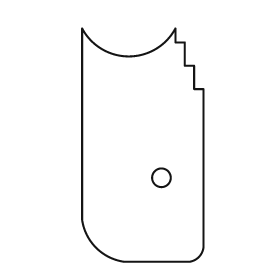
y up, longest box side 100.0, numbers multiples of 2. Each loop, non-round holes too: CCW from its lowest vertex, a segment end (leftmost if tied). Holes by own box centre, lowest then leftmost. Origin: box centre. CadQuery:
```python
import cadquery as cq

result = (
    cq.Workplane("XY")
    .moveTo(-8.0, -50.0)
    .lineTo(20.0, -50.0)
    .threePointArc((24.0, -48.0), (26.0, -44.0))
    .lineTo(26.0, 24.0)
    .lineTo(22.0, 24.0)
    .lineTo(22.0, 34.0)
    .lineTo(18.0, 34.0)
    .lineTo(18.0, 44.0)
    .lineTo(14.0, 44.0)
    .lineTo(14.0, 50.0)
    .threePointArc((-6.0, 38.0), (-26.0, 50.0))
    .lineTo(-26.0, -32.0)
    .threePointArc((-20.0, -44.0), (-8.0, -50.0))
    .close()
    .moveTo(8.0, -14.0)
    .circle(4.0)
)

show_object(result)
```